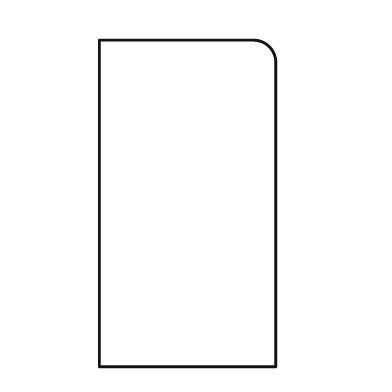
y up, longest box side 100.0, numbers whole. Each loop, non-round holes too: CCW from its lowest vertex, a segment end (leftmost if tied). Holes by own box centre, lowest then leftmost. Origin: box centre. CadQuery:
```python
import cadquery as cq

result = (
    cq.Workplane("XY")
    .moveTo(-27.0, -50.0)
    .lineTo(27.0, -50.0)
    .lineTo(27.0, 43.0)
    .threePointArc((25.0, 48.0), (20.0, 50.0))
    .lineTo(-27.0, 50.0)
    .close()
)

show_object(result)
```